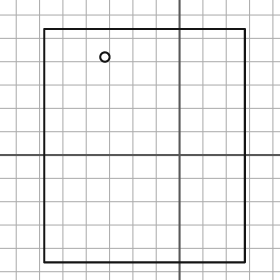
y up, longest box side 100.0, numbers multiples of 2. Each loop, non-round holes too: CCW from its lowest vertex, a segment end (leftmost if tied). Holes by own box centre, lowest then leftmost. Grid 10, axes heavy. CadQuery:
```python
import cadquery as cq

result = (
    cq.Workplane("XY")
    .moveTo(-58.0, -46.0)
    .lineTo(28.0, -46.0)
    .lineTo(28.0, 54.0)
    .lineTo(-58.0, 54.0)
    .close()
    .moveTo(-32.0, 42.0)
    .circle(2.0)
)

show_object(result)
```